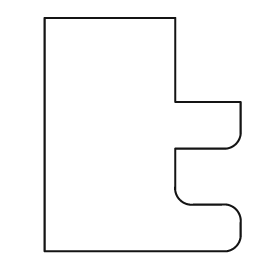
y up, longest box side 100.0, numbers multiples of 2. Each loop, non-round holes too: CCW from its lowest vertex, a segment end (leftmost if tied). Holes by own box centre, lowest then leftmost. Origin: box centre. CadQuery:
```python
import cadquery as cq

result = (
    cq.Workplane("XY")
    .moveTo(-42.0, -50.0)
    .lineTo(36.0, -50.0)
    .threePointArc((40.0, -48.0), (42.0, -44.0))
    .lineTo(42.0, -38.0)
    .threePointArc((40.0, -32.0), (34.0, -30.0))
    .lineTo(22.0, -30.0)
    .threePointArc((16.0, -28.0), (14.0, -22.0))
    .lineTo(14.0, -6.0)
    .lineTo(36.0, -6.0)
    .threePointArc((40.0, -4.0), (42.0, 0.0))
    .lineTo(42.0, 14.0)
    .lineTo(14.0, 14.0)
    .lineTo(14.0, 50.0)
    .lineTo(-42.0, 50.0)
    .close()
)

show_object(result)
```